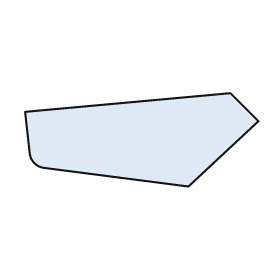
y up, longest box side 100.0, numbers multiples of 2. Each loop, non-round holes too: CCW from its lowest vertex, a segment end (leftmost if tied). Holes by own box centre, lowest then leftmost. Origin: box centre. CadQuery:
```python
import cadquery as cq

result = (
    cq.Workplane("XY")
    .moveTo(20.0, -20.0)
    .lineTo(50.0, 8.0)
    .lineTo(38.0, 20.0)
    .lineTo(-50.0, 12.0)
    .lineTo(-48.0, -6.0)
    .threePointArc((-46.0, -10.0), (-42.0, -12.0))
    .close()
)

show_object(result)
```